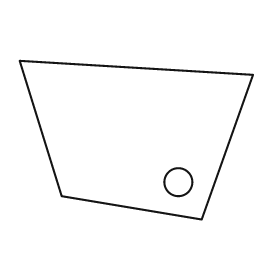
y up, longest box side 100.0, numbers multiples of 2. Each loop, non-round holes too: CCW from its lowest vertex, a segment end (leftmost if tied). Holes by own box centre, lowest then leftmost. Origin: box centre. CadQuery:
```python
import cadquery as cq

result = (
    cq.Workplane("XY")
    .moveTo(28.0, -34.0)
    .lineTo(50.0, 28.0)
    .lineTo(-50.0, 34.0)
    .lineTo(-32.0, -24.0)
    .close()
    .moveTo(18.0, -18.0)
    .circle(6.0)
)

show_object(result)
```